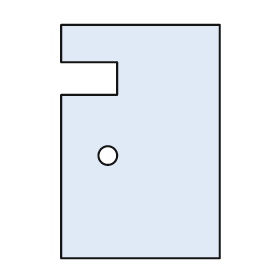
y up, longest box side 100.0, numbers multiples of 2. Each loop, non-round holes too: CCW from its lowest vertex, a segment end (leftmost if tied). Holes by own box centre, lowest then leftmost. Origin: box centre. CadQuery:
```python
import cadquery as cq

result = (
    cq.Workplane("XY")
    .moveTo(-34.0, -50.0)
    .lineTo(34.0, -50.0)
    .lineTo(34.0, 50.0)
    .lineTo(-34.0, 50.0)
    .lineTo(-34.0, 34.0)
    .lineTo(-10.0, 34.0)
    .lineTo(-10.0, 20.0)
    .lineTo(-34.0, 20.0)
    .close()
    .moveTo(-14.0, -6.0)
    .circle(4.0)
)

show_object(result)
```